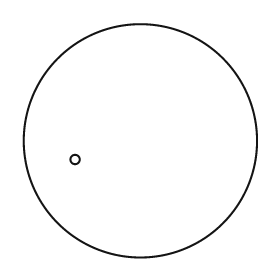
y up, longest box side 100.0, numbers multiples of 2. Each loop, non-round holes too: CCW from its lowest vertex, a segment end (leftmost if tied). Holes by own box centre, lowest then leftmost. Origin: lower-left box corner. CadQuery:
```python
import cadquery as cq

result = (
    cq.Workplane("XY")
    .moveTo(50.0, 50.0)
    .circle(50.0)
    .moveTo(22.0, 42.0)
    .circle(2.0)
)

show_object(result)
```